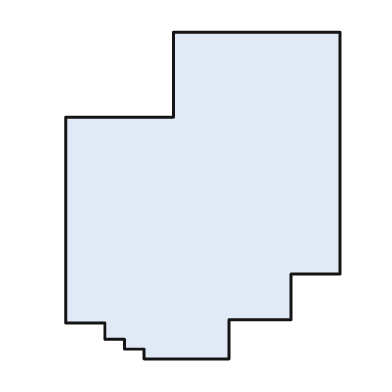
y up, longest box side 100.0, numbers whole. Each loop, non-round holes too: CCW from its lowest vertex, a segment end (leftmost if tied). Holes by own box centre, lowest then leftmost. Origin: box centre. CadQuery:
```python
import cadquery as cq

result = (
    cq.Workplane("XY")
    .moveTo(-18.0, -50.0)
    .lineTo(8.0, -50.0)
    .lineTo(8.0, -38.0)
    .lineTo(27.0, -38.0)
    .lineTo(27.0, -24.0)
    .lineTo(42.0, -24.0)
    .lineTo(42.0, 50.0)
    .lineTo(-9.0, 50.0)
    .lineTo(-9.0, 24.0)
    .lineTo(-42.0, 24.0)
    .lineTo(-42.0, -39.0)
    .lineTo(-30.0, -39.0)
    .lineTo(-30.0, -44.0)
    .lineTo(-24.0, -44.0)
    .lineTo(-24.0, -47.0)
    .lineTo(-18.0, -47.0)
    .close()
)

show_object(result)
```